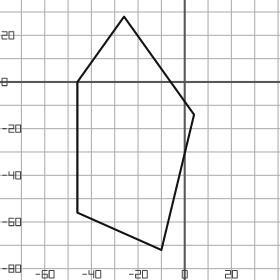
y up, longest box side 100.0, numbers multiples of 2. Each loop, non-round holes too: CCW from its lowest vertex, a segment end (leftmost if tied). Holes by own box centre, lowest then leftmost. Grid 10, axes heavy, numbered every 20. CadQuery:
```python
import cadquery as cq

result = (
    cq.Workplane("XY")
    .moveTo(-10.0, -72.0)
    .lineTo(4.0, -14.0)
    .lineTo(-26.0, 28.0)
    .lineTo(-46.0, 0.0)
    .lineTo(-46.0, -56.0)
    .close()
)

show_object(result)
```